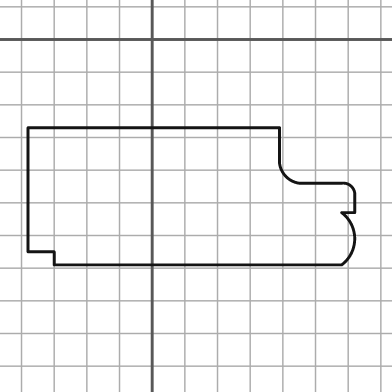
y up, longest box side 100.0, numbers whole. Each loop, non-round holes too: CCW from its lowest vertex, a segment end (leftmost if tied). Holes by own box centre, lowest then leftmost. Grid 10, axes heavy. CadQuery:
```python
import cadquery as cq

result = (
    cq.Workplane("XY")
    .moveTo(-30.0, -69.0)
    .lineTo(58.0, -69.0)
    .threePointArc((62.0, -61.0), (58.0, -53.0))
    .lineTo(62.0, -53.0)
    .lineTo(62.0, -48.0)
    .threePointArc((61.0, -45.0), (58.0, -44.0))
    .lineTo(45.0, -44.0)
    .threePointArc((41.0, -42.0), (39.0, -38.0))
    .lineTo(39.0, -27.0)
    .lineTo(-38.0, -27.0)
    .lineTo(-38.0, -65.0)
    .lineTo(-30.0, -65.0)
    .close()
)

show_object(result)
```